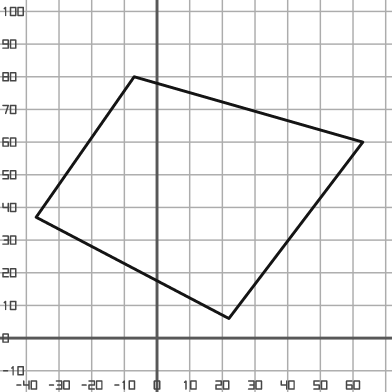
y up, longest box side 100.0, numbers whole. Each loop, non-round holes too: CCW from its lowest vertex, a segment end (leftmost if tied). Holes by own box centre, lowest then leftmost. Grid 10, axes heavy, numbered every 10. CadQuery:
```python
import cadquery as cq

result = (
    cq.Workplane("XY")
    .moveTo(22.0, 6.0)
    .lineTo(63.0, 60.0)
    .lineTo(-7.0, 80.0)
    .lineTo(-37.0, 37.0)
    .close()
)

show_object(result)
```